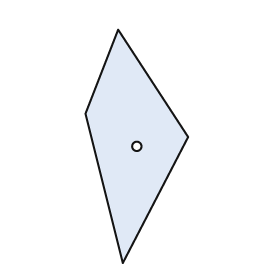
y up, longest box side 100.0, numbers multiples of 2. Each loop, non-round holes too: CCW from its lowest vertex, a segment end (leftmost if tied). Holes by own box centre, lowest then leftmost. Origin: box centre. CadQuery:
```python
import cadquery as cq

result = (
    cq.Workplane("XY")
    .moveTo(-6.0, -50.0)
    .lineTo(22.0, 4.0)
    .lineTo(-8.0, 50.0)
    .lineTo(-22.0, 14.0)
    .close()
    .moveTo(0.0, 0.0)
    .circle(2.0)
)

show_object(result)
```